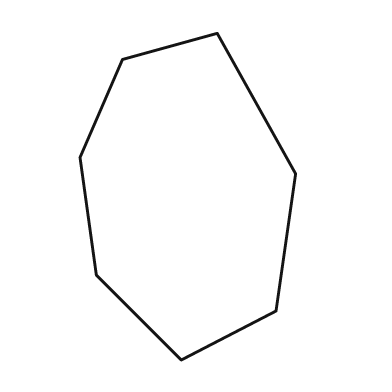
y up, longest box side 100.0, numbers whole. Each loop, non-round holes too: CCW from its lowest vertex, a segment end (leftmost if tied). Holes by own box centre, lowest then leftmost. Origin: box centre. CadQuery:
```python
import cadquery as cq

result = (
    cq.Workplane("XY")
    .moveTo(-2.0, -50.0)
    .lineTo(27.0, -35.0)
    .lineTo(33.0, 7.0)
    .lineTo(9.0, 50.0)
    .lineTo(-20.0, 42.0)
    .lineTo(-33.0, 12.0)
    .lineTo(-28.0, -24.0)
    .close()
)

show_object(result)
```